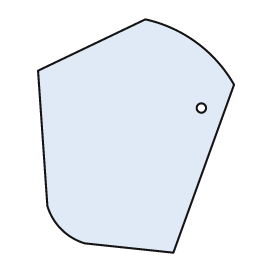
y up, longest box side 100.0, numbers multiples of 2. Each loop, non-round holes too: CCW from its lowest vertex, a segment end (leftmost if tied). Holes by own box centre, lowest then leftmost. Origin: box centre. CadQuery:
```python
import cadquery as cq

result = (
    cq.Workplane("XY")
    .moveTo(16.0, -50.0)
    .lineTo(42.0, 22.0)
    .threePointArc((26.0, 40.0), (4.0, 50.0))
    .lineTo(-42.0, 28.0)
    .lineTo(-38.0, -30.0)
    .threePointArc((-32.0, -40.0), (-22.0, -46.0))
    .close()
    .moveTo(28.0, 12.0)
    .circle(2.0)
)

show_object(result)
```